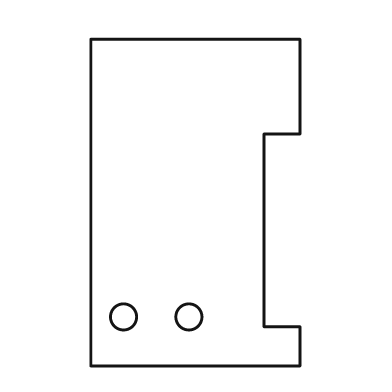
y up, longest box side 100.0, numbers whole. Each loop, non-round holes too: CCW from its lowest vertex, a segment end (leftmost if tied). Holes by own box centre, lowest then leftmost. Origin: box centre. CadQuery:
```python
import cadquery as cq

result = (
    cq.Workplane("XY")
    .moveTo(-32.0, -50.0)
    .lineTo(32.0, -50.0)
    .lineTo(32.0, -38.0)
    .lineTo(21.0, -38.0)
    .lineTo(21.0, 21.0)
    .lineTo(32.0, 21.0)
    .lineTo(32.0, 50.0)
    .lineTo(-32.0, 50.0)
    .close()
    .moveTo(-22.0, -35.0)
    .circle(4.0)
    .moveTo(-2.0, -35.0)
    .circle(4.0)
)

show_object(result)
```